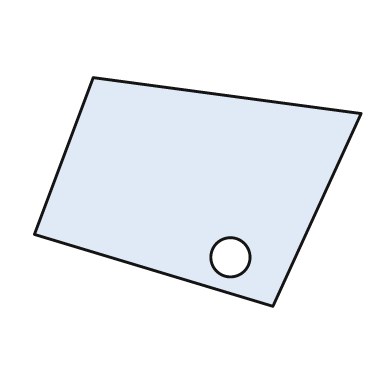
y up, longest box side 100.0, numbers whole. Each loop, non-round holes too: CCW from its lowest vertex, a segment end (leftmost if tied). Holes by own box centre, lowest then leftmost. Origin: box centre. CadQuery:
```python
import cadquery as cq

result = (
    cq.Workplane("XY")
    .moveTo(23.0, -35.0)
    .lineTo(50.0, 24.0)
    .lineTo(-32.0, 35.0)
    .lineTo(-50.0, -13.0)
    .close()
    .moveTo(10.0, -20.0)
    .circle(6.0)
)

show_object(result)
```